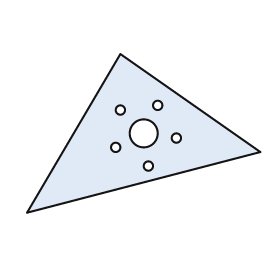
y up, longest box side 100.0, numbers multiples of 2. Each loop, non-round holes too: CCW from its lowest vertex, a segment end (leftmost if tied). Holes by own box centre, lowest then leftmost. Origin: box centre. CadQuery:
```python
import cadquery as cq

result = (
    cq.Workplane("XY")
    .moveTo(-50.0, -34.0)
    .lineTo(50.0, -8.0)
    .lineTo(-10.0, 34.0)
    .close()
    .moveTo(2.0, -14.0)
    .circle(2.0)
    .moveTo(-12.0, -6.0)
    .circle(2.0)
    .moveTo(14.0, -2.0)
    .circle(2.0)
    .moveTo(0.0, 0.0)
    .circle(6.0)
    .moveTo(-10.0, 10.0)
    .circle(2.0)
    .moveTo(6.0, 12.0)
    .circle(2.0)
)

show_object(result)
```